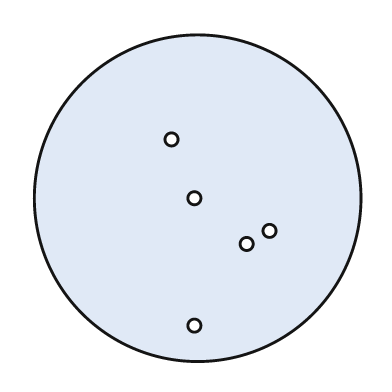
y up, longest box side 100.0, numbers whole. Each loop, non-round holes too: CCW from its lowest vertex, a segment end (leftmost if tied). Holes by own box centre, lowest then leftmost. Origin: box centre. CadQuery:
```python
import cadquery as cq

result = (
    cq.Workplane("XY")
    .moveTo(0.0, 0.0)
    .circle(50.0)
    .moveTo(-1.0, -39.0)
    .circle(2.0)
    .moveTo(15.0, -14.0)
    .circle(2.0)
    .moveTo(22.0, -10.0)
    .circle(2.0)
    .moveTo(-1.0, 0.0)
    .circle(2.0)
    .moveTo(-8.0, 18.0)
    .circle(2.0)
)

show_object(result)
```